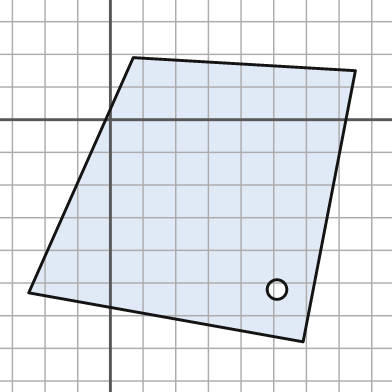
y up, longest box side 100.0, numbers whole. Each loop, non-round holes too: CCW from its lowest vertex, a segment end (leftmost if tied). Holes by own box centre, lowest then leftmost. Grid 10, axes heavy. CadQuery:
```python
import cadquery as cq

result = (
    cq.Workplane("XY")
    .moveTo(59.0, -68.0)
    .lineTo(75.0, 15.0)
    .lineTo(7.0, 19.0)
    .lineTo(-25.0, -53.0)
    .close()
    .moveTo(51.0, -52.0)
    .circle(3.0)
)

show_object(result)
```